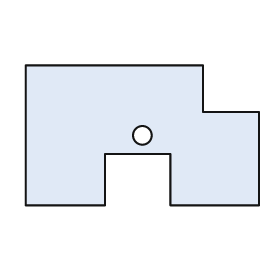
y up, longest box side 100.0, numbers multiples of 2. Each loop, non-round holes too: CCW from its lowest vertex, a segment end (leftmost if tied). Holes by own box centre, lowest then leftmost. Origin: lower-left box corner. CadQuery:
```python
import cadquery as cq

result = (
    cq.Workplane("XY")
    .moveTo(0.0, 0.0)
    .lineTo(34.0, 0.0)
    .lineTo(34.0, 22.0)
    .lineTo(62.0, 22.0)
    .lineTo(62.0, 0.0)
    .lineTo(100.0, 0.0)
    .lineTo(100.0, 40.0)
    .lineTo(76.0, 40.0)
    .lineTo(76.0, 60.0)
    .lineTo(0.0, 60.0)
    .close()
    .moveTo(50.0, 30.0)
    .circle(4.0)
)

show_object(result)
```